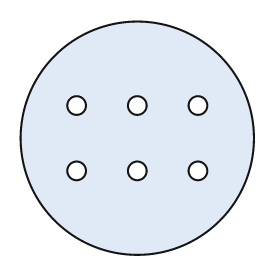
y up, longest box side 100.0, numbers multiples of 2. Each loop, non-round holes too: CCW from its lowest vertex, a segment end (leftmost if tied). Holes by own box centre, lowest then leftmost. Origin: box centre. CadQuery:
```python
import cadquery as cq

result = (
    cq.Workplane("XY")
    .moveTo(0.0, 0.0)
    .circle(50.0)
    .moveTo(-26.0, -14.0)
    .circle(4.0)
    .moveTo(0.0, -14.0)
    .circle(4.0)
    .moveTo(26.0, -14.0)
    .circle(4.0)
    .moveTo(-26.0, 14.0)
    .circle(4.0)
    .moveTo(0.0, 14.0)
    .circle(4.0)
    .moveTo(26.0, 14.0)
    .circle(4.0)
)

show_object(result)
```